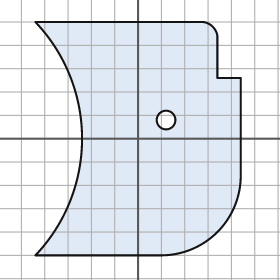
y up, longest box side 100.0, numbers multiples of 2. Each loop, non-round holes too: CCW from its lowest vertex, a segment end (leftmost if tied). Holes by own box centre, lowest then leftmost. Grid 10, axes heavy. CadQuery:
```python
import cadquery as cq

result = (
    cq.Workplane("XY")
    .moveTo(-44.0, -50.0)
    .lineTo(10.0, -50.0)
    .threePointArc((34.0, -40.0), (44.0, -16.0))
    .lineTo(44.0, 26.0)
    .lineTo(34.0, 26.0)
    .lineTo(34.0, 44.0)
    .threePointArc((32.0, 48.0), (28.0, 50.0))
    .lineTo(-44.0, 50.0)
    .threePointArc((-24.0, 0.0), (-44.0, -50.0))
    .close()
    .moveTo(12.0, 8.0)
    .circle(4.0)
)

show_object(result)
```